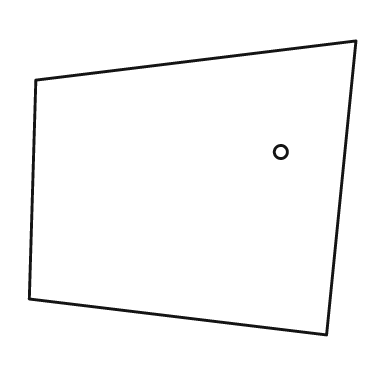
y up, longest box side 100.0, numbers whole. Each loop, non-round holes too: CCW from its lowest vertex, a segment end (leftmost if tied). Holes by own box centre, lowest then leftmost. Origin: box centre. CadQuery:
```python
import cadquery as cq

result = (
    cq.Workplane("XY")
    .moveTo(41.0, -45.0)
    .lineTo(50.0, 45.0)
    .lineTo(-48.0, 33.0)
    .lineTo(-50.0, -34.0)
    .close()
    .moveTo(27.0, 11.0)
    .circle(2.0)
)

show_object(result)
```